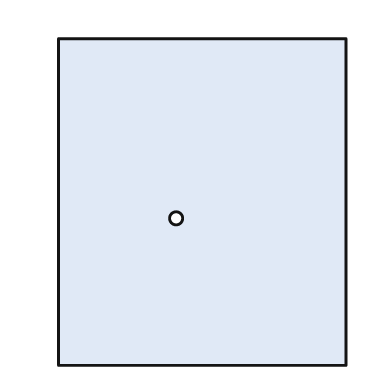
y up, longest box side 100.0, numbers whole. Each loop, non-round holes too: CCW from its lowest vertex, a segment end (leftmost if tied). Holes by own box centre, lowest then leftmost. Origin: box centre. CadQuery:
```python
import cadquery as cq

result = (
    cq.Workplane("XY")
    .moveTo(-44.0, -50.0)
    .lineTo(44.0, -50.0)
    .lineTo(44.0, 50.0)
    .lineTo(-44.0, 50.0)
    .close()
    .moveTo(-8.0, -5.0)
    .circle(2.0)
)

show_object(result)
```